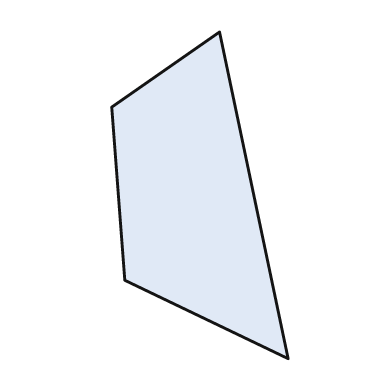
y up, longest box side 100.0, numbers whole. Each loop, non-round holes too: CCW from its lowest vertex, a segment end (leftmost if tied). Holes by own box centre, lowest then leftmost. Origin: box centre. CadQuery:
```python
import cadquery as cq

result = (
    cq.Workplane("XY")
    .moveTo(27.0, -50.0)
    .lineTo(6.0, 50.0)
    .lineTo(-27.0, 27.0)
    .lineTo(-23.0, -26.0)
    .close()
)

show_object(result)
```